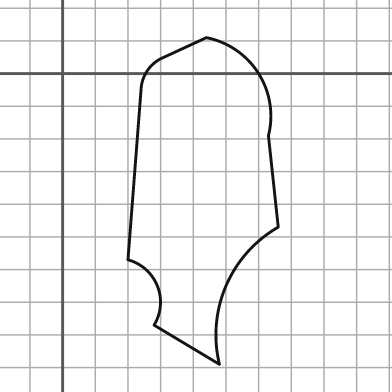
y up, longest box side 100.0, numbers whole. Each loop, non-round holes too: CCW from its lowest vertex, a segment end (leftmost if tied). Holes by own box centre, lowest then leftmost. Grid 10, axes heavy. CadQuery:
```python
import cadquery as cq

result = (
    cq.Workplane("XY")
    .moveTo(48.0, -89.0)
    .threePointArc((50.0, -65.0), (66.0, -47.0))
    .lineTo(63.0, -19.0)
    .threePointArc((60.0, 0.0), (44.0, 11.0))
    .lineTo(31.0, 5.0)
    .threePointArc((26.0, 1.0), (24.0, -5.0))
    .lineTo(20.0, -57.0)
    .threePointArc((29.0, -65.0), (28.0, -77.0))
    .close()
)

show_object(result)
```